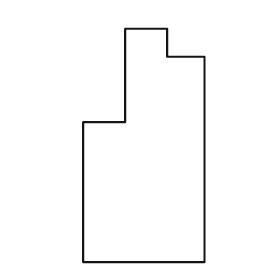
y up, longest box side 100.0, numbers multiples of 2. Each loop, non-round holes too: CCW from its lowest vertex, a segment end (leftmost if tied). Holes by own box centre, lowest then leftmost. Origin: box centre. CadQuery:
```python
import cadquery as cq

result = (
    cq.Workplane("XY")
    .moveTo(-26.0, -50.0)
    .lineTo(26.0, -50.0)
    .lineTo(26.0, 38.0)
    .lineTo(10.0, 38.0)
    .lineTo(10.0, 50.0)
    .lineTo(-8.0, 50.0)
    .lineTo(-8.0, 10.0)
    .lineTo(-26.0, 10.0)
    .close()
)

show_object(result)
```